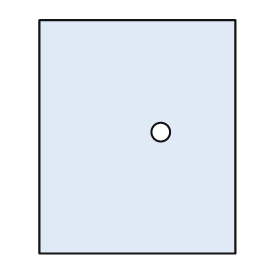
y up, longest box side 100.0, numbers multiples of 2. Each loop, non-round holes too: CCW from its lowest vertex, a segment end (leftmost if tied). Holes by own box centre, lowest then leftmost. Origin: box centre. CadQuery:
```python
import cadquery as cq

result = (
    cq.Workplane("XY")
    .moveTo(-42.0, -50.0)
    .lineTo(42.0, -50.0)
    .lineTo(42.0, 50.0)
    .lineTo(-42.0, 50.0)
    .close()
    .moveTo(10.0, 2.0)
    .circle(4.0)
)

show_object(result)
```